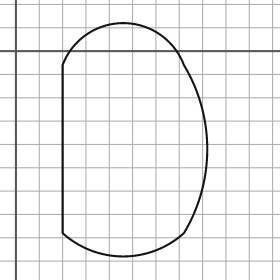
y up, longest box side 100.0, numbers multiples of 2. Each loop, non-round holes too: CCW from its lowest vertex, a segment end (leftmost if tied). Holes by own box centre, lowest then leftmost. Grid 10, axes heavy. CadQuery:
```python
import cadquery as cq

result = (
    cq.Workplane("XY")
    .moveTo(20.0, -78.0)
    .threePointArc((46.0, -88.0), (72.0, -78.0))
    .threePointArc((82.0, -42.0), (72.0, -6.0))
    .threePointArc((46.0, 12.0), (20.0, -6.0))
    .close()
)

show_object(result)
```